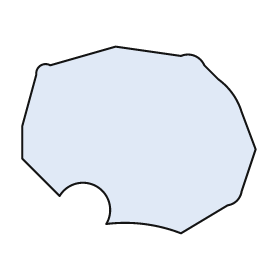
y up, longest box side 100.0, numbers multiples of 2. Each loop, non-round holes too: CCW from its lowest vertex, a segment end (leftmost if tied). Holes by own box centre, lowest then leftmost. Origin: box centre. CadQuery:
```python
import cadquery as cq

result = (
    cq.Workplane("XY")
    .moveTo(18.0, -40.0)
    .lineTo(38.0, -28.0)
    .threePointArc((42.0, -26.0), (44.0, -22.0))
    .lineTo(50.0, -4.0)
    .lineTo(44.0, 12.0)
    .threePointArc((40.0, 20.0), (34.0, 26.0))
    .lineTo(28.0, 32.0)
    .threePointArc((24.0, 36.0), (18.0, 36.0))
    .lineTo(-10.0, 40.0)
    .lineTo(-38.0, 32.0)
    .threePointArc((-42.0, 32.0), (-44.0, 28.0))
    .lineTo(-50.0, 6.0)
    .lineTo(-50.0, -8.0)
    .lineTo(-34.0, -24.0)
    .threePointArc((-18.0, -20.0), (-14.0, -36.0))
    .threePointArc((2.0, -36.0), (18.0, -40.0))
    .close()
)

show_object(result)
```